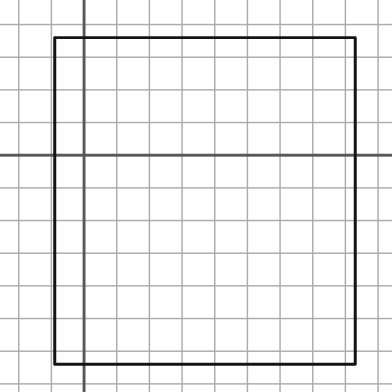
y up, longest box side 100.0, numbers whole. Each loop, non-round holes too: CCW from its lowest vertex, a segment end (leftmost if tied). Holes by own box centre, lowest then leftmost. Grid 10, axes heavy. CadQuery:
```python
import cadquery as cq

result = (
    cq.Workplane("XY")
    .moveTo(-9.0, -64.0)
    .lineTo(83.0, -64.0)
    .lineTo(83.0, 36.0)
    .lineTo(-9.0, 36.0)
    .close()
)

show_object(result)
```